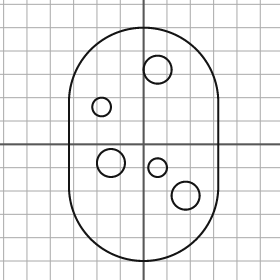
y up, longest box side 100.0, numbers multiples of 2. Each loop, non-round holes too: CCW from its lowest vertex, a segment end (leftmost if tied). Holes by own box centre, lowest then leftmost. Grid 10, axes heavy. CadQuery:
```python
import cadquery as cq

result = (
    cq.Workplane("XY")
    .moveTo(-32.0, -18.0)
    .threePointArc((0.0, -50.0), (32.0, -18.0))
    .lineTo(32.0, 18.0)
    .threePointArc((0.0, 50.0), (-32.0, 18.0))
    .close()
    .moveTo(18.0, -22.0)
    .circle(6.0)
    .moveTo(6.0, -10.0)
    .circle(4.0)
    .moveTo(-14.0, -8.0)
    .circle(6.0)
    .moveTo(-18.0, 16.0)
    .circle(4.0)
    .moveTo(6.0, 32.0)
    .circle(6.0)
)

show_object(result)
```